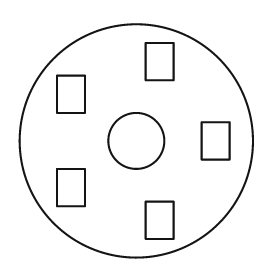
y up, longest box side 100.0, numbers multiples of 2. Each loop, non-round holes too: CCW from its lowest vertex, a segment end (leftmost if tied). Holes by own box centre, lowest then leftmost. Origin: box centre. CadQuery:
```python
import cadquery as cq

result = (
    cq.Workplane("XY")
    .moveTo(0.0, 0.0)
    .circle(50.0)
    .moveTo(4.0, -42.0)
    .lineTo(16.0, -42.0)
    .lineTo(16.0, -26.0)
    .lineTo(4.0, -26.0)
    .close()
    .moveTo(-34.0, -28.0)
    .lineTo(-22.0, -28.0)
    .lineTo(-22.0, -12.0)
    .lineTo(-34.0, -12.0)
    .close()
    .moveTo(0.0, 0.0)
    .circle(12.0)
    .moveTo(28.0, -8.0)
    .lineTo(40.0, -8.0)
    .lineTo(40.0, 8.0)
    .lineTo(28.0, 8.0)
    .close()
    .moveTo(-34.0, 12.0)
    .lineTo(-22.0, 12.0)
    .lineTo(-22.0, 28.0)
    .lineTo(-34.0, 28.0)
    .close()
    .moveTo(4.0, 26.0)
    .lineTo(16.0, 26.0)
    .lineTo(16.0, 42.0)
    .lineTo(4.0, 42.0)
    .close()
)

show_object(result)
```